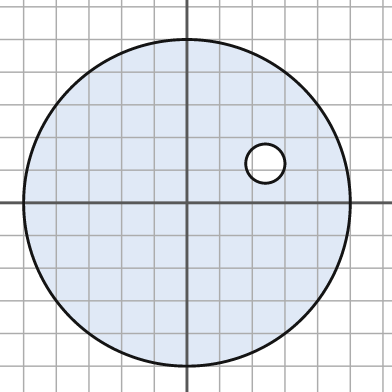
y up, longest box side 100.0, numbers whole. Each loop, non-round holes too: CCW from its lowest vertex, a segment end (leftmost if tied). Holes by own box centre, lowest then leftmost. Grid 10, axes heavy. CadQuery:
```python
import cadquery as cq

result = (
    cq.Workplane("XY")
    .moveTo(0.0, 0.0)
    .circle(50.0)
    .moveTo(24.0, 12.0)
    .circle(6.0)
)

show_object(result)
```